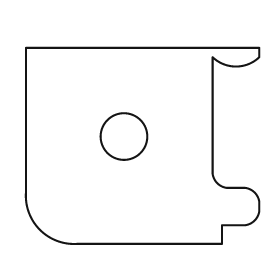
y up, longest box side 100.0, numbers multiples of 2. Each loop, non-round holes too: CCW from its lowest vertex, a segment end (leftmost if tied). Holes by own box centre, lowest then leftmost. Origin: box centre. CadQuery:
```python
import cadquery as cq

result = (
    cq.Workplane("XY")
    .moveTo(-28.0, -42.0)
    .lineTo(34.0, -42.0)
    .lineTo(34.0, -34.0)
    .lineTo(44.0, -34.0)
    .threePointArc((48.0, -32.0), (50.0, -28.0))
    .lineTo(50.0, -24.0)
    .threePointArc((48.0, -20.0), (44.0, -18.0))
    .lineTo(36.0, -18.0)
    .threePointArc((32.0, -16.0), (30.0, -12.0))
    .lineTo(30.0, 38.0)
    .threePointArc((40.0, 34.0), (50.0, 38.0))
    .lineTo(50.0, 42.0)
    .lineTo(-50.0, 42.0)
    .lineTo(-50.0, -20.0)
    .threePointArc((-44.0, -36.0), (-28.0, -42.0))
    .close()
    .moveTo(-8.0, 4.0)
    .circle(10.0)
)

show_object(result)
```